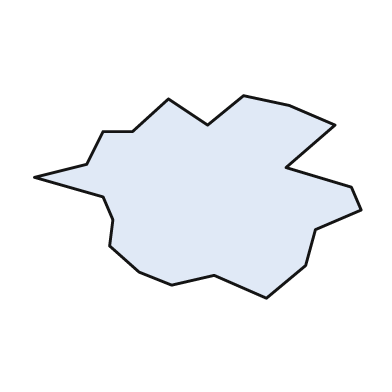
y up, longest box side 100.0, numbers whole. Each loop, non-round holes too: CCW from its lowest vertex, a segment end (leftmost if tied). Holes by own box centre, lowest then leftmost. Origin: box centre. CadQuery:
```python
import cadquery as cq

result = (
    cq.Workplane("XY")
    .moveTo(21.0, -31.0)
    .lineTo(33.0, -21.0)
    .lineTo(36.0, -10.0)
    .lineTo(50.0, -4.0)
    .lineTo(47.0, 3.0)
    .lineTo(27.0, 9.0)
    .lineTo(42.0, 22.0)
    .lineTo(28.0, 28.0)
    .lineTo(14.0, 31.0)
    .lineTo(3.0, 22.0)
    .lineTo(-9.0, 30.0)
    .lineTo(-20.0, 20.0)
    .lineTo(-29.0, 20.0)
    .lineTo(-34.0, 10.0)
    .lineTo(-50.0, 6.0)
    .lineTo(-29.0, 0.0)
    .lineTo(-26.0, -7.0)
    .lineTo(-27.0, -15.0)
    .lineTo(-18.0, -23.0)
    .lineTo(-8.0, -27.0)
    .lineTo(5.0, -24.0)
    .close()
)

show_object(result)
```